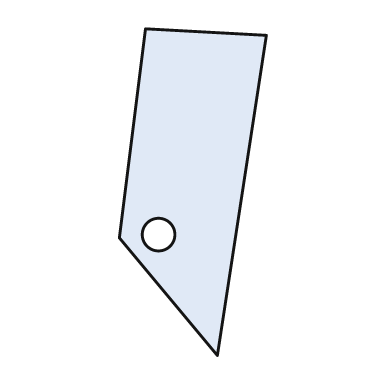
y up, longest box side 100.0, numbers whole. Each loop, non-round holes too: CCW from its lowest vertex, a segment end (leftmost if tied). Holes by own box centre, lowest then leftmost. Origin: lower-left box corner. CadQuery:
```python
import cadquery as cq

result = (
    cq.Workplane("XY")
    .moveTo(30.0, 0.0)
    .lineTo(45.0, 98.0)
    .lineTo(8.0, 100.0)
    .lineTo(0.0, 36.0)
    .close()
    .moveTo(12.0, 37.0)
    .circle(5.0)
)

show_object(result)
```